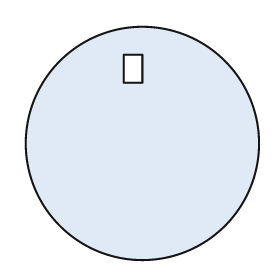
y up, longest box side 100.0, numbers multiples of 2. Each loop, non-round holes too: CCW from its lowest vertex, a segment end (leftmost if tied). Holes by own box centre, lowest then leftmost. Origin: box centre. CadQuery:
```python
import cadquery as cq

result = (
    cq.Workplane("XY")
    .moveTo(0.0, 0.0)
    .circle(50.0)
    .moveTo(-8.0, 26.0)
    .lineTo(0.0, 26.0)
    .lineTo(0.0, 38.0)
    .lineTo(-8.0, 38.0)
    .close()
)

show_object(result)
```